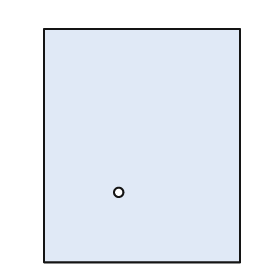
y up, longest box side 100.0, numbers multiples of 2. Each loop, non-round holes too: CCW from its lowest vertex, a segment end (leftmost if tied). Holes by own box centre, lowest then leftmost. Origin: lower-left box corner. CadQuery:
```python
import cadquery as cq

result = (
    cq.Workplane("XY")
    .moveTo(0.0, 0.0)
    .lineTo(84.0, 0.0)
    .lineTo(84.0, 100.0)
    .lineTo(0.0, 100.0)
    .close()
    .moveTo(32.0, 30.0)
    .circle(2.0)
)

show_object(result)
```